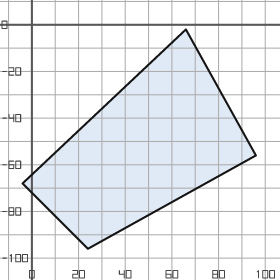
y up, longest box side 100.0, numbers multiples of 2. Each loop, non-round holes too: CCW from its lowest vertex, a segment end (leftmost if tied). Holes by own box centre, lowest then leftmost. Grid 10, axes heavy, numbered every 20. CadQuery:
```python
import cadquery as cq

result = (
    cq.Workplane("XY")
    .moveTo(24.0, -96.0)
    .lineTo(96.0, -56.0)
    .lineTo(66.0, -2.0)
    .lineTo(-4.0, -68.0)
    .close()
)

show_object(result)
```